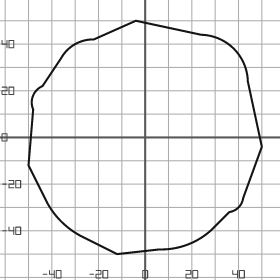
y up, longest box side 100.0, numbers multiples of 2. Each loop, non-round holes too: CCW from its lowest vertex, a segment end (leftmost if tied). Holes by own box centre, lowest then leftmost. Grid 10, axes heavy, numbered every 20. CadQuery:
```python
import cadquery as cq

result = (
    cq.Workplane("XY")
    .moveTo(-12.0, -50.0)
    .lineTo(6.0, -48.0)
    .threePointArc((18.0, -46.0), (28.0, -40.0))
    .lineTo(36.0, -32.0)
    .threePointArc((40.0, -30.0), (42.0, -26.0))
    .lineTo(50.0, -4.0)
    .lineTo(44.0, 24.0)
    .threePointArc((38.0, 38.0), (24.0, 44.0))
    .lineTo(-4.0, 50.0)
    .lineTo(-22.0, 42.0)
    .threePointArc((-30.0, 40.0), (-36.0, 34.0))
    .lineTo(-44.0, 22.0)
    .threePointArc((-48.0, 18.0), (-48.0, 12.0))
    .lineTo(-50.0, -12.0)
    .lineTo(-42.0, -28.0)
    .threePointArc((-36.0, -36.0), (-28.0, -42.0))
    .close()
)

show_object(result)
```